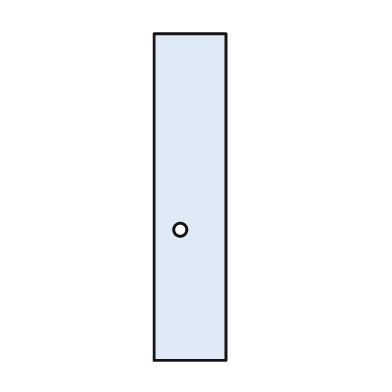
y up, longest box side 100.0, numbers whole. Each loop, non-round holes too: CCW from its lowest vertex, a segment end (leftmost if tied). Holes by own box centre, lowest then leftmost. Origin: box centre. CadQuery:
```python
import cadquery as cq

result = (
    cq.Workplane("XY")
    .moveTo(-11.0, -50.0)
    .lineTo(11.0, -50.0)
    .lineTo(11.0, 50.0)
    .lineTo(-11.0, 50.0)
    .close()
    .moveTo(-3.0, -10.0)
    .circle(2.0)
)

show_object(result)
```